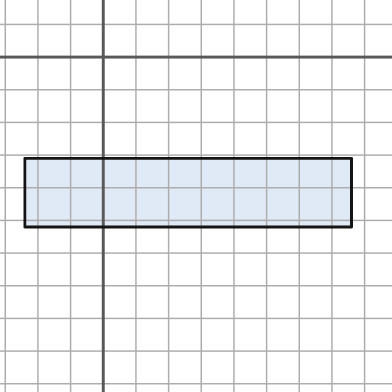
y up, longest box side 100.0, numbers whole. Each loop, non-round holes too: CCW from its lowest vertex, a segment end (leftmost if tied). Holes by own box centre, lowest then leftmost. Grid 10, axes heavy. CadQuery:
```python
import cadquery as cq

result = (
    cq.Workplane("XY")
    .moveTo(-24.0, -52.0)
    .lineTo(76.0, -52.0)
    .lineTo(76.0, -31.0)
    .lineTo(-24.0, -31.0)
    .close()
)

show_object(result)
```